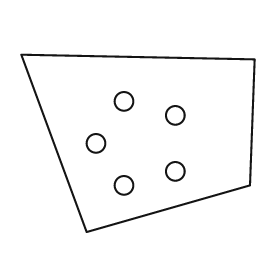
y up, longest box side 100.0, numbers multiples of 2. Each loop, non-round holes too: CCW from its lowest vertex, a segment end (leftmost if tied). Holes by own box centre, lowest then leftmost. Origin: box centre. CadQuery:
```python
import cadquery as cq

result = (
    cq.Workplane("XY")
    .moveTo(-22.0, -38.0)
    .lineTo(48.0, -18.0)
    .lineTo(50.0, 36.0)
    .lineTo(-50.0, 38.0)
    .close()
    .moveTo(-6.0, -18.0)
    .circle(4.0)
    .moveTo(16.0, -12.0)
    .circle(4.0)
    .moveTo(-18.0, 0.0)
    .circle(4.0)
    .moveTo(16.0, 12.0)
    .circle(4.0)
    .moveTo(-6.0, 18.0)
    .circle(4.0)
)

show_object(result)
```